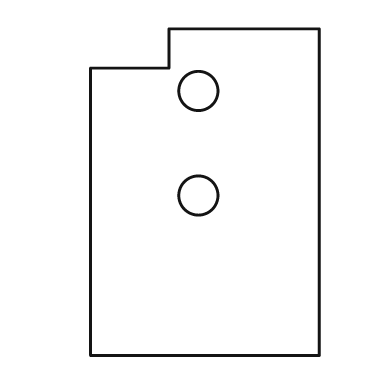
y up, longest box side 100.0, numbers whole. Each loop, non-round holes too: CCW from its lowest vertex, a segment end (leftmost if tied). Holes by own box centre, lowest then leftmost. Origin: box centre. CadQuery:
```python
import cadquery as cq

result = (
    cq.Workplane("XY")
    .moveTo(-35.0, -50.0)
    .lineTo(35.0, -50.0)
    .lineTo(35.0, 50.0)
    .lineTo(-11.0, 50.0)
    .lineTo(-11.0, 38.0)
    .lineTo(-35.0, 38.0)
    .close()
    .moveTo(-2.0, -1.0)
    .circle(6.0)
    .moveTo(-2.0, 31.0)
    .circle(6.0)
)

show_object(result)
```